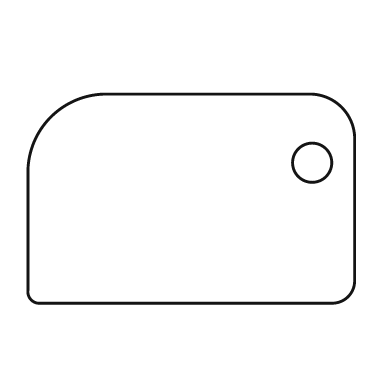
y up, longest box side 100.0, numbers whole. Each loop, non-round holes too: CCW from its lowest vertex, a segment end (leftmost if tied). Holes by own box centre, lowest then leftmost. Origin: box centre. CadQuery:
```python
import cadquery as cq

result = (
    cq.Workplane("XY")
    .moveTo(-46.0, -32.0)
    .lineTo(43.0, -32.0)
    .threePointArc((48.0, -30.0), (50.0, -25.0))
    .lineTo(50.0, 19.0)
    .threePointArc((46.0, 28.0), (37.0, 32.0))
    .lineTo(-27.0, 32.0)
    .threePointArc((-43.0, 25.0), (-50.0, 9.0))
    .lineTo(-50.0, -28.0)
    .threePointArc((-49.0, -31.0), (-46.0, -32.0))
    .close()
    .moveTo(37.0, 11.0)
    .circle(6.0)
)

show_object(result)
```